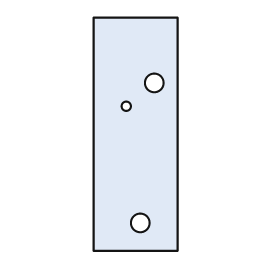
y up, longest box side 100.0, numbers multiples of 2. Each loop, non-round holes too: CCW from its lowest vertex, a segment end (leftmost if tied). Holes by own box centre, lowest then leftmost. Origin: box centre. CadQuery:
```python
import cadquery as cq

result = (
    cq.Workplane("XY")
    .moveTo(-18.0, -50.0)
    .lineTo(18.0, -50.0)
    .lineTo(18.0, 50.0)
    .lineTo(-18.0, 50.0)
    .close()
    .moveTo(2.0, -38.0)
    .circle(4.0)
    .moveTo(-4.0, 12.0)
    .circle(2.0)
    .moveTo(8.0, 22.0)
    .circle(4.0)
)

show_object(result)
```